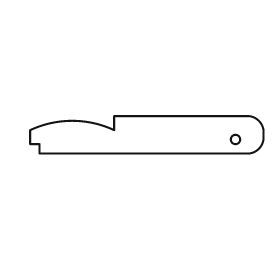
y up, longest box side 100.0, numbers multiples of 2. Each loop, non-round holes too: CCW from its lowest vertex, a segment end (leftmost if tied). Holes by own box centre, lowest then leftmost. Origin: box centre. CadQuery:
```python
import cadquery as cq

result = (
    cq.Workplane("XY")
    .moveTo(-46.0, -8.0)
    .lineTo(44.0, -8.0)
    .threePointArc((48.0, -6.0), (50.0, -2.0))
    .lineTo(50.0, 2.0)
    .threePointArc((48.0, 6.0), (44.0, 8.0))
    .lineTo(-14.0, 8.0)
    .lineTo(-14.0, 2.0)
    .threePointArc((-32.0, 6.0), (-50.0, 2.0))
    .lineTo(-50.0, -4.0)
    .lineTo(-46.0, -4.0)
    .close()
    .moveTo(38.0, -2.0)
    .circle(2.0)
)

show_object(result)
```